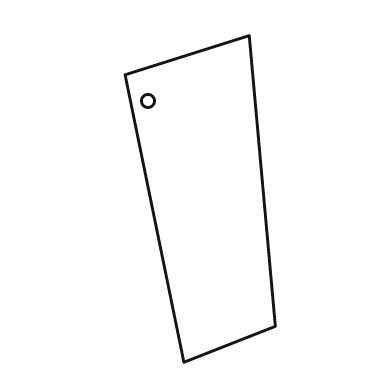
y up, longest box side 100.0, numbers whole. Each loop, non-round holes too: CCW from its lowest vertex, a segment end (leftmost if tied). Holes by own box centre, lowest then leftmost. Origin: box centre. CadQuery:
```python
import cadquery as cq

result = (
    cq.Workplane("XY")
    .moveTo(-5.0, -50.0)
    .lineTo(23.0, -39.0)
    .lineTo(15.0, 50.0)
    .lineTo(-23.0, 38.0)
    .close()
    .moveTo(-16.0, 30.0)
    .circle(2.0)
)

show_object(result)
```